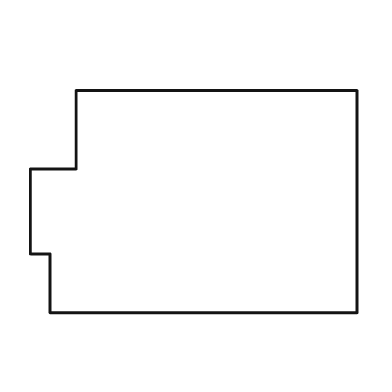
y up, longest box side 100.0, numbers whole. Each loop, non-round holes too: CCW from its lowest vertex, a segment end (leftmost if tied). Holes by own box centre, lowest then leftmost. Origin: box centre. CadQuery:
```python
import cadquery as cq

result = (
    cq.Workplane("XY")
    .moveTo(-44.0, -34.0)
    .lineTo(50.0, -34.0)
    .lineTo(50.0, 34.0)
    .lineTo(-36.0, 34.0)
    .lineTo(-36.0, 10.0)
    .lineTo(-50.0, 10.0)
    .lineTo(-50.0, -16.0)
    .lineTo(-44.0, -16.0)
    .close()
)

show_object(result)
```